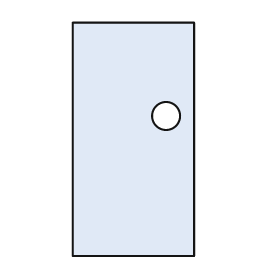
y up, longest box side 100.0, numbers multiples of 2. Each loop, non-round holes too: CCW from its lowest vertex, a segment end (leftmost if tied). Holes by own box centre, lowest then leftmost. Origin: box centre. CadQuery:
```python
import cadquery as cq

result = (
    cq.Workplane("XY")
    .moveTo(-26.0, -50.0)
    .lineTo(26.0, -50.0)
    .lineTo(26.0, 50.0)
    .lineTo(-26.0, 50.0)
    .close()
    .moveTo(14.0, 10.0)
    .circle(6.0)
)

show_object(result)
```